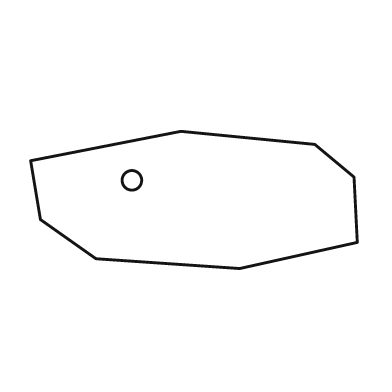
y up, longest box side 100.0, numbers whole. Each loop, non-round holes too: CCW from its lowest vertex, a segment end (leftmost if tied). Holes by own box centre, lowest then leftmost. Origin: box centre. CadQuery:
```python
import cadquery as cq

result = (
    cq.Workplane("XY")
    .moveTo(14.0, -21.0)
    .lineTo(50.0, -13.0)
    .lineTo(49.0, 7.0)
    .lineTo(37.0, 17.0)
    .lineTo(-4.0, 21.0)
    .lineTo(-50.0, 12.0)
    .lineTo(-47.0, -6.0)
    .lineTo(-30.0, -18.0)
    .close()
    .moveTo(-19.0, 6.0)
    .circle(3.0)
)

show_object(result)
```